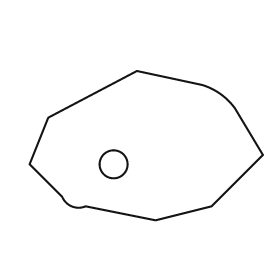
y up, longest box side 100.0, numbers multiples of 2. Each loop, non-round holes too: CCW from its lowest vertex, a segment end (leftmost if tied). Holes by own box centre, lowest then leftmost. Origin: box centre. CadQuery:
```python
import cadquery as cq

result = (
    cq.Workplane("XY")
    .moveTo(4.0, -32.0)
    .lineTo(28.0, -26.0)
    .lineTo(50.0, -4.0)
    .lineTo(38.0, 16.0)
    .threePointArc((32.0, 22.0), (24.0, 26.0))
    .lineTo(-4.0, 32.0)
    .lineTo(-42.0, 12.0)
    .lineTo(-50.0, -8.0)
    .lineTo(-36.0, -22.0)
    .threePointArc((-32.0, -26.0), (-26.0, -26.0))
    .close()
    .moveTo(-14.0, -8.0)
    .circle(6.0)
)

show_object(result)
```